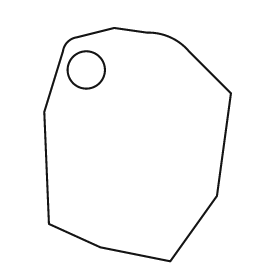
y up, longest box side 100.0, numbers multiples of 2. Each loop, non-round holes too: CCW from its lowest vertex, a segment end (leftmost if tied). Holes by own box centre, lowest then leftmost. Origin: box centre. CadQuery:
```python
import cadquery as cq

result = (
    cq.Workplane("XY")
    .moveTo(14.0, -50.0)
    .lineTo(34.0, -22.0)
    .lineTo(40.0, 22.0)
    .lineTo(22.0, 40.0)
    .threePointArc((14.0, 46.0), (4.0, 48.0))
    .lineTo(-10.0, 50.0)
    .lineTo(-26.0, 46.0)
    .threePointArc((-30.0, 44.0), (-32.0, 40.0))
    .lineTo(-40.0, 14.0)
    .lineTo(-38.0, -34.0)
    .lineTo(-16.0, -44.0)
    .close()
    .moveTo(-22.0, 32.0)
    .circle(8.0)
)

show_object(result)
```